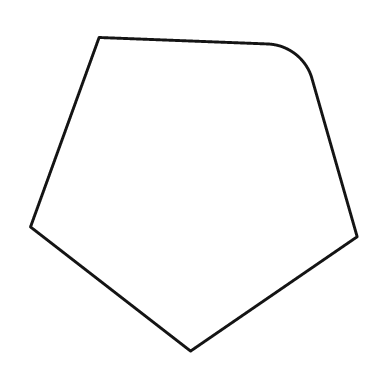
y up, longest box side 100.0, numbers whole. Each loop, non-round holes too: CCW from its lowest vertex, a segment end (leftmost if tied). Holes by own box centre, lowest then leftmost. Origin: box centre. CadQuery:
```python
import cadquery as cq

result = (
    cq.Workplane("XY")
    .moveTo(-1.0, -48.0)
    .lineTo(50.0, -13.0)
    .lineTo(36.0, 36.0)
    .threePointArc((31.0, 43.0), (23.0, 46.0))
    .lineTo(-29.0, 48.0)
    .lineTo(-50.0, -10.0)
    .close()
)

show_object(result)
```